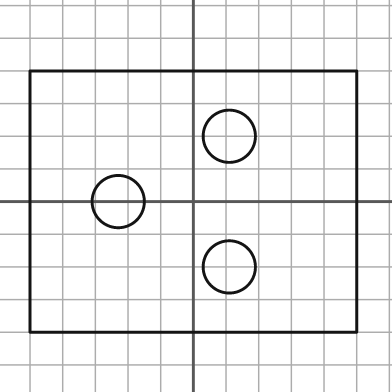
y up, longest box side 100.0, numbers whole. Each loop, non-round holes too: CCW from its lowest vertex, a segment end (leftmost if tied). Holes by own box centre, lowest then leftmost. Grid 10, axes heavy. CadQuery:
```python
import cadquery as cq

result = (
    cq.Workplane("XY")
    .moveTo(-50.0, -40.0)
    .lineTo(50.0, -40.0)
    .lineTo(50.0, 40.0)
    .lineTo(-50.0, 40.0)
    .close()
    .moveTo(11.0, -20.0)
    .circle(8.0)
    .moveTo(-23.0, 0.0)
    .circle(8.0)
    .moveTo(11.0, 20.0)
    .circle(8.0)
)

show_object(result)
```